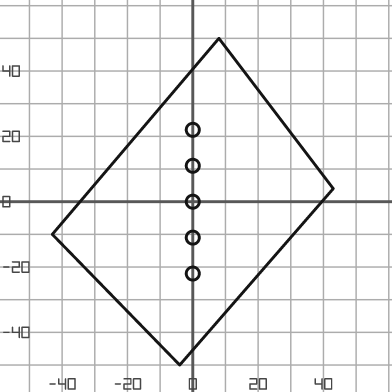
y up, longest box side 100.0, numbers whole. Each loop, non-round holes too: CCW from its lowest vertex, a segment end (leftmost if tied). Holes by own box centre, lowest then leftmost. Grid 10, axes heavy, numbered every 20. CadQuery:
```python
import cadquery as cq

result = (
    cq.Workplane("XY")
    .moveTo(-4.0, -50.0)
    .lineTo(43.0, 4.0)
    .lineTo(8.0, 50.0)
    .lineTo(-43.0, -10.0)
    .close()
    .moveTo(0.0, -22.0)
    .circle(2.0)
    .moveTo(0.0, -11.0)
    .circle(2.0)
    .moveTo(0.0, 0.0)
    .circle(2.0)
    .moveTo(0.0, 11.0)
    .circle(2.0)
    .moveTo(0.0, 22.0)
    .circle(2.0)
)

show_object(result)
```